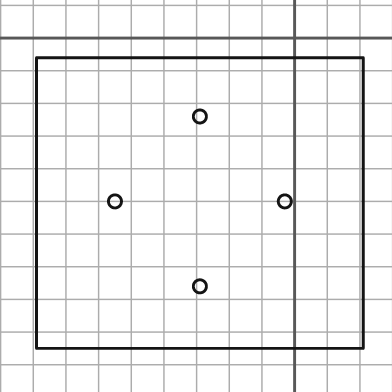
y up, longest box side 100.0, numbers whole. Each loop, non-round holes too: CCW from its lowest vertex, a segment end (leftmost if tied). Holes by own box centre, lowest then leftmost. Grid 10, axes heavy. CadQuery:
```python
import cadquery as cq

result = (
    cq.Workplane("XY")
    .moveTo(-79.0, -95.0)
    .lineTo(21.0, -95.0)
    .lineTo(21.0, -6.0)
    .lineTo(-79.0, -6.0)
    .close()
    .moveTo(-29.0, -76.0)
    .circle(2.0)
    .moveTo(-55.0, -50.0)
    .circle(2.0)
    .moveTo(-3.0, -50.0)
    .circle(2.0)
    .moveTo(-29.0, -24.0)
    .circle(2.0)
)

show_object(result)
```